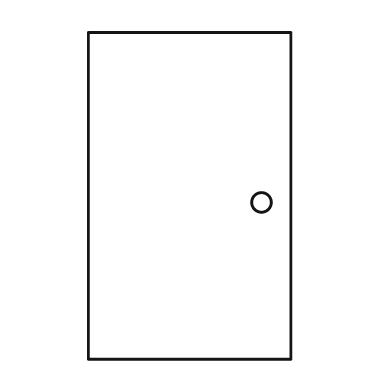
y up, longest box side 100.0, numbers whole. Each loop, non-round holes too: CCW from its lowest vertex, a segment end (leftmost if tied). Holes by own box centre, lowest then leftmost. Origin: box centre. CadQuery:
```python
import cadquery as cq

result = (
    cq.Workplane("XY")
    .moveTo(-31.0, -50.0)
    .lineTo(31.0, -50.0)
    .lineTo(31.0, 50.0)
    .lineTo(-31.0, 50.0)
    .close()
    .moveTo(22.0, -2.0)
    .circle(3.0)
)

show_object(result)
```